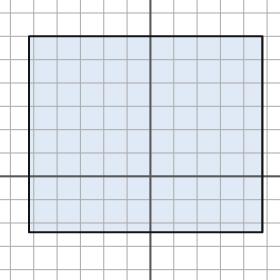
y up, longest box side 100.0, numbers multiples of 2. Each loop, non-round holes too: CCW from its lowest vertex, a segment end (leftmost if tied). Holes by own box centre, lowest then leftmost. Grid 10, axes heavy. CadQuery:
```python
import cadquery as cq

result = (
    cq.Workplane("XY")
    .moveTo(-52.0, -24.0)
    .lineTo(48.0, -24.0)
    .lineTo(48.0, 60.0)
    .lineTo(-52.0, 60.0)
    .close()
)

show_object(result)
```